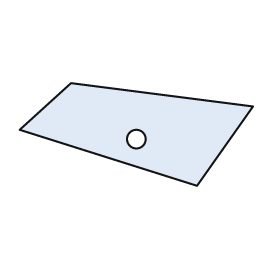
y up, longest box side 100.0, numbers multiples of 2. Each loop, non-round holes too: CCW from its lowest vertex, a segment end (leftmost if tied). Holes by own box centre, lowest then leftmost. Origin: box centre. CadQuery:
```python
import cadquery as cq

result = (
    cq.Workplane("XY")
    .moveTo(26.0, -22.0)
    .lineTo(50.0, 12.0)
    .lineTo(-28.0, 22.0)
    .lineTo(-50.0, 2.0)
    .close()
    .moveTo(0.0, -2.0)
    .circle(4.0)
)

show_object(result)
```